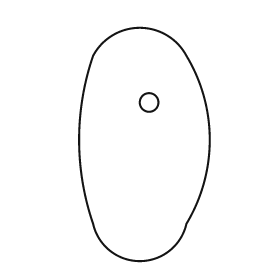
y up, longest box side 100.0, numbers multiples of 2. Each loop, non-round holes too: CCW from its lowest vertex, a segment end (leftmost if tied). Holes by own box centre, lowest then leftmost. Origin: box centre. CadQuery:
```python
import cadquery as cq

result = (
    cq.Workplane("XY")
    .moveTo(-22.0, -34.0)
    .threePointArc((-2.0, -50.0), (18.0, -34.0))
    .threePointArc((28.0, 2.0), (18.0, 38.0))
    .threePointArc((-2.0, 50.0), (-22.0, 38.0))
    .threePointArc((-28.0, 2.0), (-22.0, -34.0))
    .close()
    .moveTo(2.0, 18.0)
    .circle(4.0)
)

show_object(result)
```